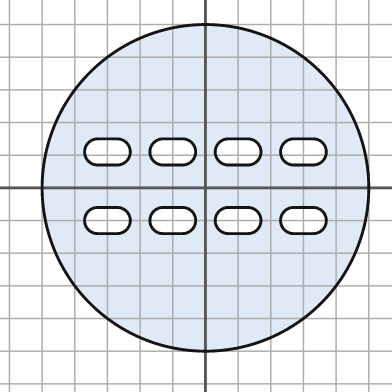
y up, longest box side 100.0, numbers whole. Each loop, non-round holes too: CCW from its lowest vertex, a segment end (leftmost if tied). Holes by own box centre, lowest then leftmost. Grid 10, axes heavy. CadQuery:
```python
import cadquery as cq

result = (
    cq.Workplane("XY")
    .moveTo(0.0, 0.0)
    .circle(50.0)
    .moveTo(-33.0, -14.0)
    .lineTo(-27.0, -14.0)
    .threePointArc((-23.0, -10.0), (-27.0, -6.0))
    .lineTo(-33.0, -6.0)
    .threePointArc((-37.0, -10.0), (-33.0, -14.0))
    .close()
    .moveTo(-13.0, -14.0)
    .lineTo(-7.0, -14.0)
    .threePointArc((-3.0, -10.0), (-7.0, -6.0))
    .lineTo(-13.0, -6.0)
    .threePointArc((-17.0, -10.0), (-13.0, -14.0))
    .close()
    .moveTo(7.0, -14.0)
    .lineTo(13.0, -14.0)
    .threePointArc((17.0, -10.0), (13.0, -6.0))
    .lineTo(7.0, -6.0)
    .threePointArc((3.0, -10.0), (7.0, -14.0))
    .close()
    .moveTo(27.0, -14.0)
    .lineTo(33.0, -14.0)
    .threePointArc((37.0, -10.0), (33.0, -6.0))
    .lineTo(27.0, -6.0)
    .threePointArc((23.0, -10.0), (27.0, -14.0))
    .close()
    .moveTo(-33.0, 7.0)
    .lineTo(-27.0, 7.0)
    .threePointArc((-23.0, 11.0), (-27.0, 15.0))
    .lineTo(-33.0, 15.0)
    .threePointArc((-37.0, 11.0), (-33.0, 7.0))
    .close()
    .moveTo(-13.0, 7.0)
    .lineTo(-7.0, 7.0)
    .threePointArc((-3.0, 11.0), (-7.0, 15.0))
    .lineTo(-13.0, 15.0)
    .threePointArc((-17.0, 11.0), (-13.0, 7.0))
    .close()
    .moveTo(7.0, 7.0)
    .lineTo(13.0, 7.0)
    .threePointArc((17.0, 11.0), (13.0, 15.0))
    .lineTo(7.0, 15.0)
    .threePointArc((3.0, 11.0), (7.0, 7.0))
    .close()
    .moveTo(27.0, 7.0)
    .lineTo(33.0, 7.0)
    .threePointArc((37.0, 11.0), (33.0, 15.0))
    .lineTo(27.0, 15.0)
    .threePointArc((23.0, 11.0), (27.0, 7.0))
    .close()
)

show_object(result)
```